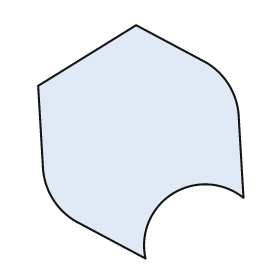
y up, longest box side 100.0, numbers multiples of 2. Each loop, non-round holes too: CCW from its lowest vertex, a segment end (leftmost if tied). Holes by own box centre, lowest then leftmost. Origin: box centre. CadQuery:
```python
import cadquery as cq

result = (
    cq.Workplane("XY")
    .moveTo(2.0, -50.0)
    .threePointArc((14.0, -22.0), (44.0, -24.0))
    .lineTo(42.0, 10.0)
    .threePointArc((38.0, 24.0), (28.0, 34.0))
    .lineTo(-2.0, 50.0)
    .lineTo(-44.0, 24.0)
    .lineTo(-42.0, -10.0)
    .threePointArc((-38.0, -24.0), (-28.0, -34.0))
    .close()
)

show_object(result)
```